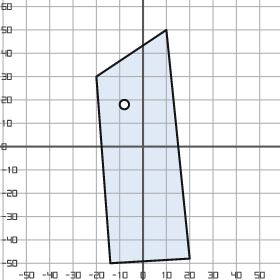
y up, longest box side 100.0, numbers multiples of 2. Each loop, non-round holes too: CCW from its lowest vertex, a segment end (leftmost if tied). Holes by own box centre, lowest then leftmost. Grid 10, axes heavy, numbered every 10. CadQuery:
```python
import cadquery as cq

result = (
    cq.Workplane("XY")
    .moveTo(-14.0, -50.0)
    .lineTo(20.0, -48.0)
    .lineTo(10.0, 50.0)
    .lineTo(-20.0, 30.0)
    .close()
    .moveTo(-8.0, 18.0)
    .circle(2.0)
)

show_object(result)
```